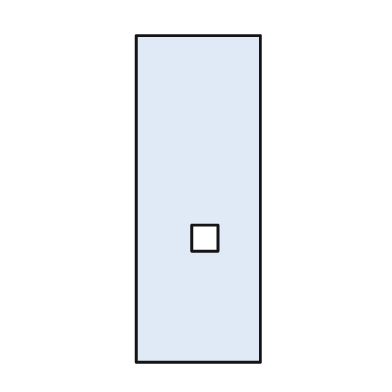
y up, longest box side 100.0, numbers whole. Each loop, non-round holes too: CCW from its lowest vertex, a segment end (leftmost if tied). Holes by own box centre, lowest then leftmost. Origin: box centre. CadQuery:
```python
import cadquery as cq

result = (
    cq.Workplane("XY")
    .moveTo(-19.0, -50.0)
    .lineTo(19.0, -50.0)
    .lineTo(19.0, 50.0)
    .lineTo(-19.0, 50.0)
    .close()
    .moveTo(-2.0, -16.0)
    .lineTo(6.0, -16.0)
    .lineTo(6.0, -8.0)
    .lineTo(-2.0, -8.0)
    .close()
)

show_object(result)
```